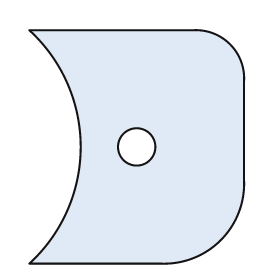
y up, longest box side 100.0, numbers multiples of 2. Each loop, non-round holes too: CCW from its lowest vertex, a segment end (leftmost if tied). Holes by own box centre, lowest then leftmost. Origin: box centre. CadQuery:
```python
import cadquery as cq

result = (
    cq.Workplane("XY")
    .moveTo(-46.0, -50.0)
    .lineTo(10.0, -50.0)
    .threePointArc((36.0, -40.0), (46.0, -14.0))
    .lineTo(46.0, 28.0)
    .threePointArc((40.0, 44.0), (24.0, 50.0))
    .lineTo(-46.0, 50.0)
    .threePointArc((-24.0, 0.0), (-46.0, -50.0))
    .close()
    .moveTo(0.0, 0.0)
    .circle(8.0)
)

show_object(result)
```